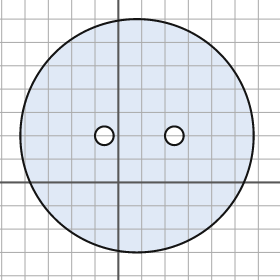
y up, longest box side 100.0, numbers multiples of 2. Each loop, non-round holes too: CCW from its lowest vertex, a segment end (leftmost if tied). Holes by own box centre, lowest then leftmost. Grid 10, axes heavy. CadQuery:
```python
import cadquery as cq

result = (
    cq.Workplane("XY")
    .moveTo(8.0, 20.0)
    .circle(50.0)
    .moveTo(-6.0, 20.0)
    .circle(4.0)
    .moveTo(24.0, 20.0)
    .circle(4.0)
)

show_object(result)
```